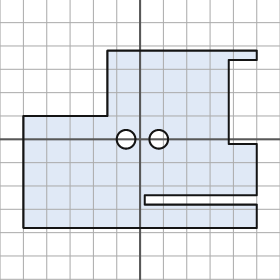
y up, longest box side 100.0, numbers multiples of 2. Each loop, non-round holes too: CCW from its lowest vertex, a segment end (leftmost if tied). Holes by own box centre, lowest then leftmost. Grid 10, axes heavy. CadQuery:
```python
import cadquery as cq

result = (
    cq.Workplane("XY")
    .moveTo(-50.0, -38.0)
    .lineTo(50.0, -38.0)
    .lineTo(50.0, -28.0)
    .lineTo(2.0, -28.0)
    .lineTo(2.0, -24.0)
    .lineTo(50.0, -24.0)
    .lineTo(50.0, -2.0)
    .lineTo(38.0, -2.0)
    .lineTo(38.0, 34.0)
    .lineTo(50.0, 34.0)
    .lineTo(50.0, 38.0)
    .lineTo(-14.0, 38.0)
    .lineTo(-14.0, 10.0)
    .lineTo(-50.0, 10.0)
    .close()
    .moveTo(-6.0, 0.0)
    .circle(4.0)
    .moveTo(8.0, 0.0)
    .circle(4.0)
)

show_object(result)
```